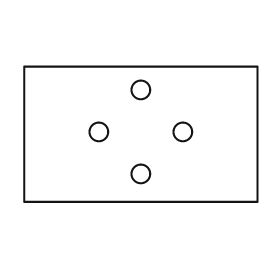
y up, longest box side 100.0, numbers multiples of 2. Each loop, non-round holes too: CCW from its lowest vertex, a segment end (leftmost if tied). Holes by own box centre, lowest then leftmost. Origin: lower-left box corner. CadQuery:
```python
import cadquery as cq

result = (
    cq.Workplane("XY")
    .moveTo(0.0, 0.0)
    .lineTo(100.0, 0.0)
    .lineTo(100.0, 58.0)
    .lineTo(0.0, 58.0)
    .close()
    .moveTo(50.0, 12.0)
    .circle(4.0)
    .moveTo(32.0, 30.0)
    .circle(4.0)
    .moveTo(68.0, 30.0)
    .circle(4.0)
    .moveTo(50.0, 48.0)
    .circle(4.0)
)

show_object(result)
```